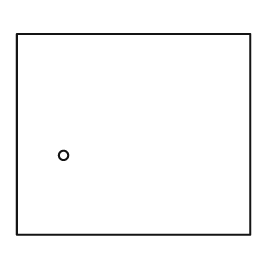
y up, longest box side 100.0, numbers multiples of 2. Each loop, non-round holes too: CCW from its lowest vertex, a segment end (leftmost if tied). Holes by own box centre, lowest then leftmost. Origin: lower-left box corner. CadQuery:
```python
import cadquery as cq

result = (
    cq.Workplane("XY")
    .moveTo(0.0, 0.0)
    .lineTo(100.0, 0.0)
    .lineTo(100.0, 86.0)
    .lineTo(0.0, 86.0)
    .close()
    .moveTo(20.0, 34.0)
    .circle(2.0)
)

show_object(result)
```